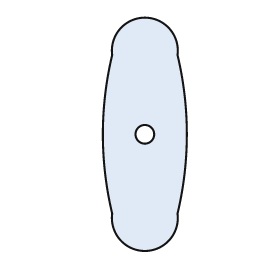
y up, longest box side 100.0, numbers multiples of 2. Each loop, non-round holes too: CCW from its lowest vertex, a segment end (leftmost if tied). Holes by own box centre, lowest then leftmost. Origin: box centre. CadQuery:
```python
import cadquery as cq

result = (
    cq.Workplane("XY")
    .moveTo(-14.0, -34.0)
    .threePointArc((0.0, -50.0), (14.0, -34.0))
    .threePointArc((18.0, 0.0), (14.0, 34.0))
    .threePointArc((0.0, 50.0), (-14.0, 34.0))
    .threePointArc((-18.0, 0.0), (-14.0, -34.0))
    .close()
    .moveTo(0.0, 0.0)
    .circle(4.0)
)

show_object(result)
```